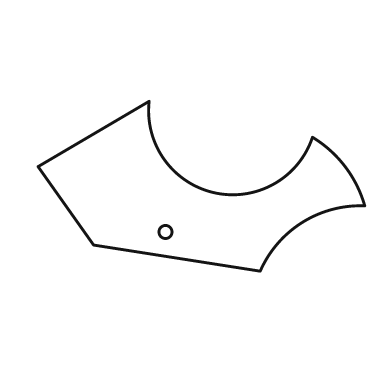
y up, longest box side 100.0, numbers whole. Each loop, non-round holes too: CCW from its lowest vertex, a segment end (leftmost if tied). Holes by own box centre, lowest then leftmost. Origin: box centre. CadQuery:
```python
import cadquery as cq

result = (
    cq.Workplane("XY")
    .moveTo(18.0, -26.0)
    .threePointArc((31.0, -11.0), (50.0, -6.0))
    .threePointArc((44.0, 6.0), (34.0, 15.0))
    .threePointArc((4.0, -2.0), (-16.0, 26.0))
    .lineTo(-50.0, 6.0)
    .lineTo(-33.0, -18.0)
    .close()
    .moveTo(-11.0, -14.0)
    .circle(2.0)
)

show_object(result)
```